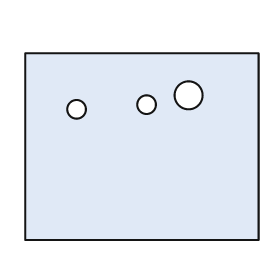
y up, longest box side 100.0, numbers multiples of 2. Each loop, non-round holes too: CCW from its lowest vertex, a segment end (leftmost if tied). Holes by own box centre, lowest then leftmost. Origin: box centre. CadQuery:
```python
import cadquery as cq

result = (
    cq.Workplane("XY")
    .moveTo(-50.0, -40.0)
    .lineTo(50.0, -40.0)
    .lineTo(50.0, 40.0)
    .lineTo(-50.0, 40.0)
    .close()
    .moveTo(-28.0, 16.0)
    .circle(4.0)
    .moveTo(2.0, 18.0)
    .circle(4.0)
    .moveTo(20.0, 22.0)
    .circle(6.0)
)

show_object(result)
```